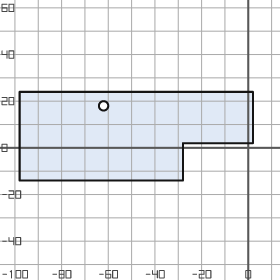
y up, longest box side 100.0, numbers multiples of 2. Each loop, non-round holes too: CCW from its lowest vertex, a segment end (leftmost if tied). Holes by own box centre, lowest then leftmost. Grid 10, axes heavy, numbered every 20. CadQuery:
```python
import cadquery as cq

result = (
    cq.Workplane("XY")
    .moveTo(-98.0, -14.0)
    .lineTo(-28.0, -14.0)
    .lineTo(-28.0, 2.0)
    .lineTo(2.0, 2.0)
    .lineTo(2.0, 24.0)
    .lineTo(-98.0, 24.0)
    .close()
    .moveTo(-62.0, 18.0)
    .circle(2.0)
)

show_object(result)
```